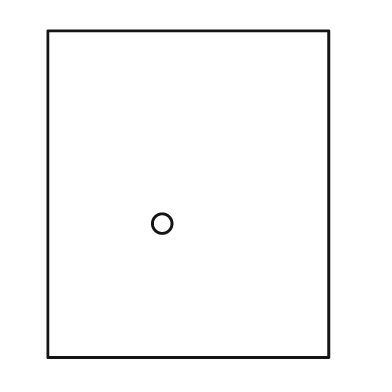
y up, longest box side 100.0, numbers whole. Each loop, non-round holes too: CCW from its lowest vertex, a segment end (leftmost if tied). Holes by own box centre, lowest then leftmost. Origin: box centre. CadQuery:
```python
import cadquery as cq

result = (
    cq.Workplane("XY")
    .moveTo(-43.0, -50.0)
    .lineTo(43.0, -50.0)
    .lineTo(43.0, 50.0)
    .lineTo(-43.0, 50.0)
    .close()
    .moveTo(-8.0, -9.0)
    .circle(3.0)
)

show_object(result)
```